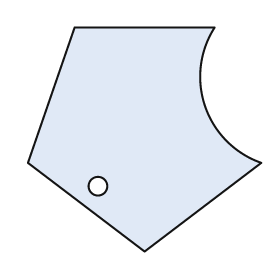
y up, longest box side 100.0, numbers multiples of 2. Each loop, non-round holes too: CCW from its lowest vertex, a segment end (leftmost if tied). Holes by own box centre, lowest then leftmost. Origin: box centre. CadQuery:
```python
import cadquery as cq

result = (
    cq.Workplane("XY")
    .moveTo(0.0, -48.0)
    .lineTo(50.0, -10.0)
    .threePointArc((26.0, 14.0), (30.0, 48.0))
    .lineTo(-30.0, 48.0)
    .lineTo(-50.0, -10.0)
    .close()
    .moveTo(-20.0, -20.0)
    .circle(4.0)
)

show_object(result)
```